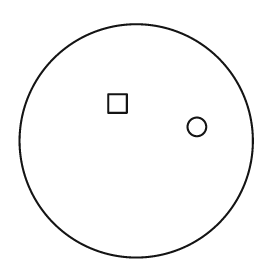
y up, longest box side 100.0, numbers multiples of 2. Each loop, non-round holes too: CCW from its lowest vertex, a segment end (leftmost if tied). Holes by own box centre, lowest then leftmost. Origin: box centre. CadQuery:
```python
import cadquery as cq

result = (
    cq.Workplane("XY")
    .moveTo(0.0, 0.0)
    .circle(50.0)
    .moveTo(26.0, 6.0)
    .circle(4.0)
    .moveTo(-12.0, 12.0)
    .lineTo(-4.0, 12.0)
    .lineTo(-4.0, 20.0)
    .lineTo(-12.0, 20.0)
    .close()
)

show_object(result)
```